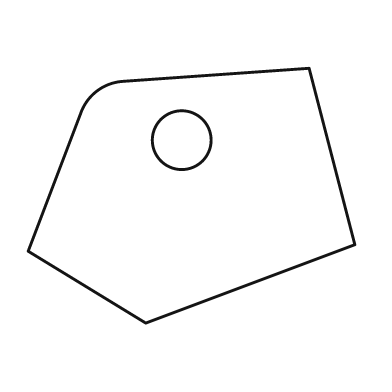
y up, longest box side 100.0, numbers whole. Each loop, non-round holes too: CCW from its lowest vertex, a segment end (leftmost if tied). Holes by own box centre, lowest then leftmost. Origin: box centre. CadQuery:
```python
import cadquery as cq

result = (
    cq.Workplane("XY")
    .moveTo(-14.0, -39.0)
    .lineTo(50.0, -15.0)
    .lineTo(36.0, 39.0)
    .lineTo(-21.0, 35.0)
    .threePointArc((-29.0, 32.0), (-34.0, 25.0))
    .lineTo(-50.0, -17.0)
    .close()
    .moveTo(-3.0, 17.0)
    .circle(9.0)
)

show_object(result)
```